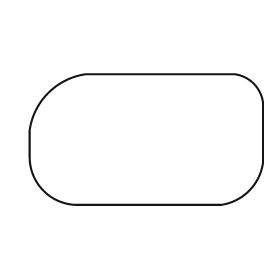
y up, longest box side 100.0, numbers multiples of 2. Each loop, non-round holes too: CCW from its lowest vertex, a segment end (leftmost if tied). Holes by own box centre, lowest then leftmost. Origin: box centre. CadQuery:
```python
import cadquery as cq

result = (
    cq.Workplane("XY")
    .moveTo(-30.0, -28.0)
    .lineTo(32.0, -28.0)
    .threePointArc((44.0, -22.0), (50.0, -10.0))
    .lineTo(50.0, 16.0)
    .threePointArc((46.0, 24.0), (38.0, 28.0))
    .lineTo(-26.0, 28.0)
    .threePointArc((-42.0, 20.0), (-50.0, 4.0))
    .lineTo(-50.0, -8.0)
    .threePointArc((-44.0, -22.0), (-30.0, -28.0))
    .close()
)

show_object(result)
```